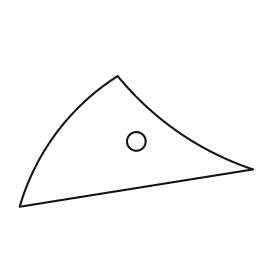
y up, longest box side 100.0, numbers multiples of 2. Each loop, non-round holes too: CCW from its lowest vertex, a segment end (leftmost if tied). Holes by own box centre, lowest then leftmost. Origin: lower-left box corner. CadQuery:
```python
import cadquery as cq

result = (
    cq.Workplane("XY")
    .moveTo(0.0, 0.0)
    .lineTo(100.0, 16.0)
    .threePointArc((68.0, 32.0), (42.0, 56.0))
    .threePointArc((16.0, 32.0), (0.0, 0.0))
    .close()
    .moveTo(50.0, 28.0)
    .circle(4.0)
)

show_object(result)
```